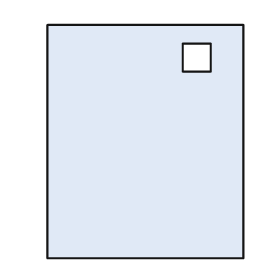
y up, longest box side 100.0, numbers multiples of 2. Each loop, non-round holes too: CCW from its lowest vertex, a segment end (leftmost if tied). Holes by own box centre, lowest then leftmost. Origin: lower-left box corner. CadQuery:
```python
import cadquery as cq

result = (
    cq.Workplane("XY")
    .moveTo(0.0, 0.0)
    .lineTo(84.0, 0.0)
    .lineTo(84.0, 100.0)
    .lineTo(0.0, 100.0)
    .close()
    .moveTo(58.0, 80.0)
    .lineTo(70.0, 80.0)
    .lineTo(70.0, 92.0)
    .lineTo(58.0, 92.0)
    .close()
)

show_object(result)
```